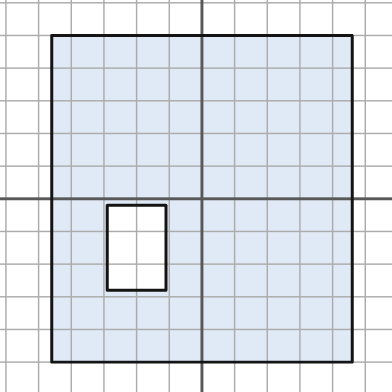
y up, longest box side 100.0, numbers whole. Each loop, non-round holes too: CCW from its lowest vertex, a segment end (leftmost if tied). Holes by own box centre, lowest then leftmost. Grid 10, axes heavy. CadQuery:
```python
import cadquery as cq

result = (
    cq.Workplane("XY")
    .moveTo(-46.0, -50.0)
    .lineTo(46.0, -50.0)
    .lineTo(46.0, 50.0)
    .lineTo(-46.0, 50.0)
    .close()
    .moveTo(-29.0, -28.0)
    .lineTo(-11.0, -28.0)
    .lineTo(-11.0, -2.0)
    .lineTo(-29.0, -2.0)
    .close()
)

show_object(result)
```